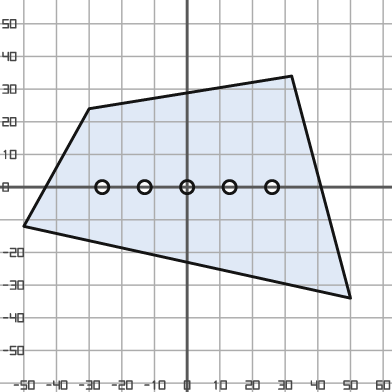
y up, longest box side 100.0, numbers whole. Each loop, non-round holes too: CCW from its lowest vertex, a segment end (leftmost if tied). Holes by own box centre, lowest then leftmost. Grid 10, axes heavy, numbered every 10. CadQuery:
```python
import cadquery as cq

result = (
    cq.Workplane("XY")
    .moveTo(50.0, -34.0)
    .lineTo(32.0, 34.0)
    .lineTo(-30.0, 24.0)
    .lineTo(-50.0, -12.0)
    .close()
    .moveTo(-26.0, 0.0)
    .circle(2.0)
    .moveTo(-13.0, 0.0)
    .circle(2.0)
    .moveTo(0.0, 0.0)
    .circle(2.0)
    .moveTo(13.0, 0.0)
    .circle(2.0)
    .moveTo(26.0, 0.0)
    .circle(2.0)
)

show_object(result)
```